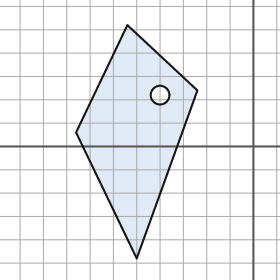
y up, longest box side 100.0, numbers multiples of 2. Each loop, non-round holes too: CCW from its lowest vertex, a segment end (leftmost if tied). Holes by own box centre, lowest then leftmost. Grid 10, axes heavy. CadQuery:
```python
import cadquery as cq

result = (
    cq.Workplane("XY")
    .moveTo(-50.0, -48.0)
    .lineTo(-24.0, 24.0)
    .lineTo(-54.0, 52.0)
    .lineTo(-76.0, 6.0)
    .close()
    .moveTo(-40.0, 22.0)
    .circle(4.0)
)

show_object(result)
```